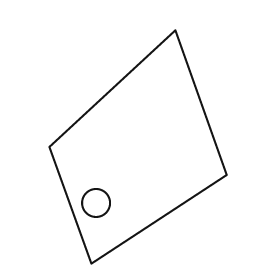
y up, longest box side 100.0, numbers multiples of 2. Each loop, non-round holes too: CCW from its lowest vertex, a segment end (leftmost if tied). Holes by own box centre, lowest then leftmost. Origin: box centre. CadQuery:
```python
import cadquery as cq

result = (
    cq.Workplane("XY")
    .moveTo(-20.0, -50.0)
    .lineTo(38.0, -12.0)
    .lineTo(16.0, 50.0)
    .lineTo(-38.0, 0.0)
    .close()
    .moveTo(-18.0, -24.0)
    .circle(6.0)
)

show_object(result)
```